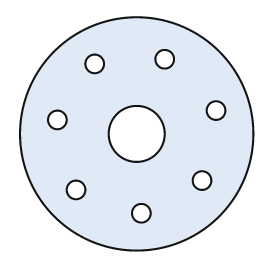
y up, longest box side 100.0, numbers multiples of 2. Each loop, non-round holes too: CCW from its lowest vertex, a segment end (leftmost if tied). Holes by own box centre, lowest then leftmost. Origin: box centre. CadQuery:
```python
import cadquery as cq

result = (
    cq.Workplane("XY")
    .moveTo(0.0, 0.0)
    .circle(50.0)
    .moveTo(2.0, -34.0)
    .circle(4.0)
    .moveTo(-26.0, -24.0)
    .circle(4.0)
    .moveTo(28.0, -20.0)
    .circle(4.0)
    .moveTo(0.0, 0.0)
    .circle(12.0)
    .moveTo(-34.0, 6.0)
    .circle(4.0)
    .moveTo(34.0, 10.0)
    .circle(4.0)
    .moveTo(-18.0, 30.0)
    .circle(4.0)
    .moveTo(12.0, 32.0)
    .circle(4.0)
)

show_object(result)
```